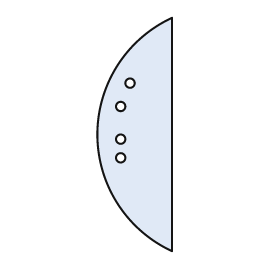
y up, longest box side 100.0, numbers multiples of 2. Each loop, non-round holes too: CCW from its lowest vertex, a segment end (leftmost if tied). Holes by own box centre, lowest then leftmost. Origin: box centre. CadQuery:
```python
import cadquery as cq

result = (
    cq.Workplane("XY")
    .moveTo(16.0, -50.0)
    .lineTo(16.0, 50.0)
    .threePointArc((-16.0, 0.0), (16.0, -50.0))
    .close()
    .moveTo(-6.0, -10.0)
    .circle(2.0)
    .moveTo(-6.0, -2.0)
    .circle(2.0)
    .moveTo(-6.0, 12.0)
    .circle(2.0)
    .moveTo(-2.0, 22.0)
    .circle(2.0)
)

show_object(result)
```